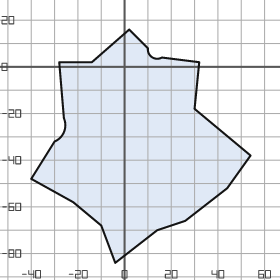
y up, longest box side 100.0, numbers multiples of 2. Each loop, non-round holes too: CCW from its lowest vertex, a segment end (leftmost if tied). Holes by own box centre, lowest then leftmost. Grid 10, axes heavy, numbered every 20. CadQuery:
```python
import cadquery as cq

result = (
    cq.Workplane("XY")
    .moveTo(-4.0, -84.0)
    .lineTo(14.0, -70.0)
    .lineTo(26.0, -66.0)
    .lineTo(44.0, -52.0)
    .lineTo(54.0, -38.0)
    .lineTo(30.0, -18.0)
    .lineTo(32.0, 2.0)
    .lineTo(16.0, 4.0)
    .threePointArc((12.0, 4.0), (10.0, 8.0))
    .lineTo(2.0, 16.0)
    .lineTo(-14.0, 2.0)
    .lineTo(-28.0, 2.0)
    .lineTo(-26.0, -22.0)
    .threePointArc((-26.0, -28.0), (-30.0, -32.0))
    .lineTo(-40.0, -48.0)
    .lineTo(-22.0, -58.0)
    .lineTo(-10.0, -68.0)
    .close()
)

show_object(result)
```